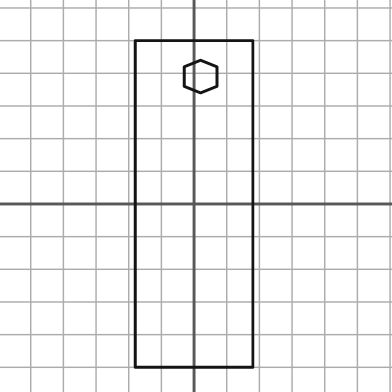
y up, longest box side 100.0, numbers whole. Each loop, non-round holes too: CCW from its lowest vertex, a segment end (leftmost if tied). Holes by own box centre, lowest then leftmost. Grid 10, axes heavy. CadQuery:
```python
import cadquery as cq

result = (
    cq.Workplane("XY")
    .moveTo(-18.0, -50.0)
    .lineTo(18.0, -50.0)
    .lineTo(18.0, 50.0)
    .lineTo(-18.0, 50.0)
    .close()
    .moveTo(2.0, 34.0)
    .lineTo(7.0, 36.0)
    .lineTo(7.0, 42.0)
    .lineTo(2.0, 44.0)
    .lineTo(-3.0, 42.0)
    .lineTo(-3.0, 36.0)
    .close()
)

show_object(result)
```